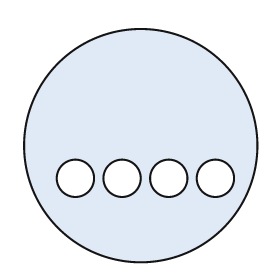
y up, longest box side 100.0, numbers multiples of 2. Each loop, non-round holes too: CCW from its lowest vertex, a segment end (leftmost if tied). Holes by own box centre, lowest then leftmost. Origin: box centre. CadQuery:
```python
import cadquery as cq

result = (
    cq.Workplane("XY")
    .moveTo(0.0, 0.0)
    .circle(50.0)
    .moveTo(-28.0, -14.0)
    .circle(8.0)
    .moveTo(-8.0, -14.0)
    .circle(8.0)
    .moveTo(12.0, -14.0)
    .circle(8.0)
    .moveTo(32.0, -14.0)
    .circle(8.0)
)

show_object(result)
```